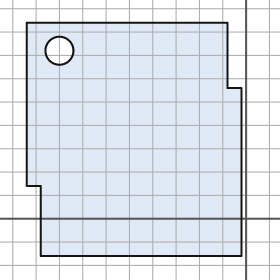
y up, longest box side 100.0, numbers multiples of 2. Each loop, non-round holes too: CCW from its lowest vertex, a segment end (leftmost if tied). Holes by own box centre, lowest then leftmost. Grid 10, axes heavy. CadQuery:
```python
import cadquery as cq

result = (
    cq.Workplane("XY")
    .moveTo(-88.0, -16.0)
    .lineTo(-2.0, -16.0)
    .lineTo(-2.0, 56.0)
    .lineTo(-8.0, 56.0)
    .lineTo(-8.0, 84.0)
    .lineTo(-94.0, 84.0)
    .lineTo(-94.0, 14.0)
    .lineTo(-88.0, 14.0)
    .close()
    .moveTo(-80.0, 72.0)
    .circle(6.0)
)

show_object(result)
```